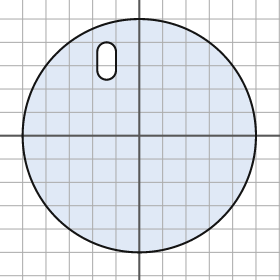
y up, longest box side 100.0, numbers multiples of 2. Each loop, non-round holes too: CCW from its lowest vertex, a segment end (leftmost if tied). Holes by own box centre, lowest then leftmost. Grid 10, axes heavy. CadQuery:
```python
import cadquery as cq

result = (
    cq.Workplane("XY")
    .moveTo(0.0, 0.0)
    .circle(50.0)
    .moveTo(-18.0, 28.0)
    .threePointArc((-14.0, 24.0), (-10.0, 28.0))
    .lineTo(-10.0, 36.0)
    .threePointArc((-14.0, 40.0), (-18.0, 36.0))
    .close()
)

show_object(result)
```